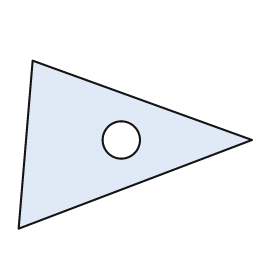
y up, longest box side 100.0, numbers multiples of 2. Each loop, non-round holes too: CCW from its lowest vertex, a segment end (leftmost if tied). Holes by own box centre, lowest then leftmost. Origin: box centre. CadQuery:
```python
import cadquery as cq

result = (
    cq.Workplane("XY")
    .moveTo(-50.0, -36.0)
    .lineTo(50.0, 2.0)
    .lineTo(-44.0, 36.0)
    .close()
    .moveTo(-6.0, 2.0)
    .circle(8.0)
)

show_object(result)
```